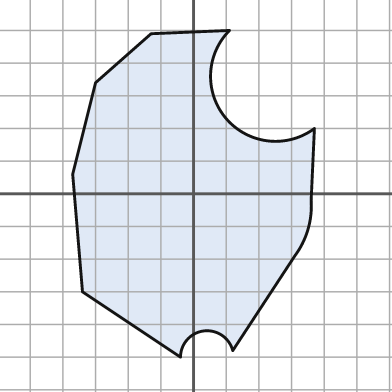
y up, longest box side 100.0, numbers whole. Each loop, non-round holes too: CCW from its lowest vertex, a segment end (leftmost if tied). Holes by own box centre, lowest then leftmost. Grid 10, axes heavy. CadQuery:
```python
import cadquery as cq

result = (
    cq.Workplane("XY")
    .moveTo(-4.0, -50.0)
    .threePointArc((3.0, -42.0), (12.0, -48.0))
    .lineTo(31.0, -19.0)
    .threePointArc((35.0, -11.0), (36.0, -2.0))
    .lineTo(37.0, 20.0)
    .threePointArc((10.0, 23.0), (11.0, 50.0))
    .lineTo(-13.0, 49.0)
    .lineTo(-30.0, 34.0)
    .lineTo(-37.0, 6.0)
    .lineTo(-34.0, -30.0)
    .close()
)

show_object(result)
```